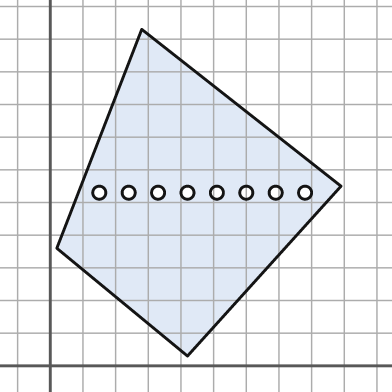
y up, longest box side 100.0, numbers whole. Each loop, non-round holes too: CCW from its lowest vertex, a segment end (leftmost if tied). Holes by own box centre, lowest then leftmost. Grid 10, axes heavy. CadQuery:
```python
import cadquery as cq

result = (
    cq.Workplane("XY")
    .moveTo(42.0, 3.0)
    .lineTo(89.0, 55.0)
    .lineTo(28.0, 103.0)
    .lineTo(2.0, 36.0)
    .close()
    .moveTo(15.0, 53.0)
    .circle(2.0)
    .moveTo(24.0, 53.0)
    .circle(2.0)
    .moveTo(33.0, 53.0)
    .circle(2.0)
    .moveTo(42.0, 53.0)
    .circle(2.0)
    .moveTo(51.0, 53.0)
    .circle(2.0)
    .moveTo(60.0, 53.0)
    .circle(2.0)
    .moveTo(69.0, 53.0)
    .circle(2.0)
    .moveTo(78.0, 53.0)
    .circle(2.0)
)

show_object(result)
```